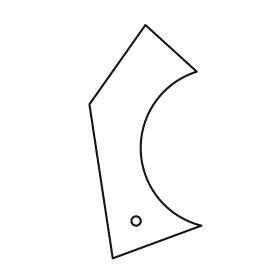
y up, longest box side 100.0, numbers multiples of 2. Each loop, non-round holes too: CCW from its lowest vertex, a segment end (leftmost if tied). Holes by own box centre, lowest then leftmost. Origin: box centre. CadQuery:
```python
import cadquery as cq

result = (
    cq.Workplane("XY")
    .moveTo(-14.0, -50.0)
    .lineTo(24.0, -36.0)
    .threePointArc((-2.0, -4.0), (22.0, 30.0))
    .lineTo(0.0, 50.0)
    .lineTo(-24.0, 16.0)
    .close()
    .moveTo(-4.0, -34.0)
    .circle(2.0)
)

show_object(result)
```